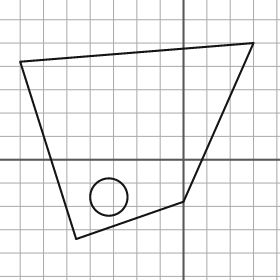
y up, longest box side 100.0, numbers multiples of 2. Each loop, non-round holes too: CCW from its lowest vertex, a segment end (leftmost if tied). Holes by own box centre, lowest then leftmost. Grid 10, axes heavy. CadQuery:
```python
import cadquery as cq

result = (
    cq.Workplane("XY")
    .moveTo(-46.0, -34.0)
    .lineTo(0.0, -18.0)
    .lineTo(30.0, 50.0)
    .lineTo(-70.0, 42.0)
    .close()
    .moveTo(-32.0, -16.0)
    .circle(8.0)
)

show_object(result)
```